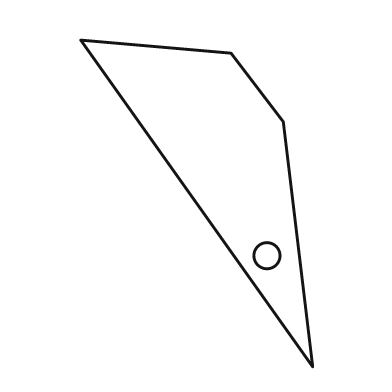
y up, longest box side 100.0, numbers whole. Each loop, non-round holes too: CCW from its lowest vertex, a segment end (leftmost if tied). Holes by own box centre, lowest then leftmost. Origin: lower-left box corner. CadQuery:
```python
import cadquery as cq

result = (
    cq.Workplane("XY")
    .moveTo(71.0, 0.0)
    .lineTo(62.0, 75.0)
    .lineTo(46.0, 96.0)
    .lineTo(0.0, 100.0)
    .close()
    .moveTo(57.0, 34.0)
    .circle(4.0)
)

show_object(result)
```